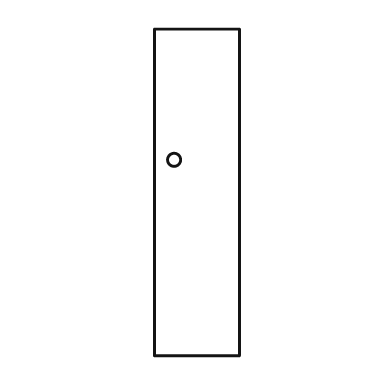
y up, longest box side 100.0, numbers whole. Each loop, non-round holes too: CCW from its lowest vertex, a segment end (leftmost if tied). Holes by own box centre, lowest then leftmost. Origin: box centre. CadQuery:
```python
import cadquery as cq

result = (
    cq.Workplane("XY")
    .moveTo(-13.0, -50.0)
    .lineTo(13.0, -50.0)
    .lineTo(13.0, 50.0)
    .lineTo(-13.0, 50.0)
    .close()
    .moveTo(-7.0, 10.0)
    .circle(2.0)
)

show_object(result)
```